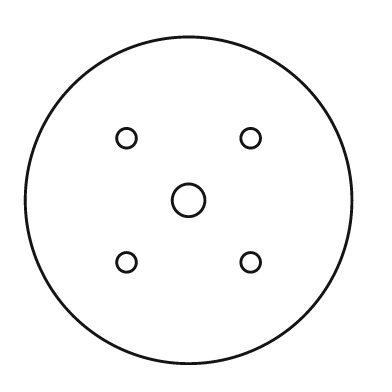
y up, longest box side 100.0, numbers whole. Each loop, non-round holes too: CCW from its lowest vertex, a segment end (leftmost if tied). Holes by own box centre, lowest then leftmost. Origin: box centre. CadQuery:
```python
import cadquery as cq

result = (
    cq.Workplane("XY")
    .moveTo(0.0, 0.0)
    .circle(50.0)
    .moveTo(-19.0, -19.0)
    .circle(3.0)
    .moveTo(19.0, -19.0)
    .circle(3.0)
    .moveTo(0.0, 0.0)
    .circle(5.0)
    .moveTo(-19.0, 19.0)
    .circle(3.0)
    .moveTo(19.0, 19.0)
    .circle(3.0)
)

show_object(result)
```